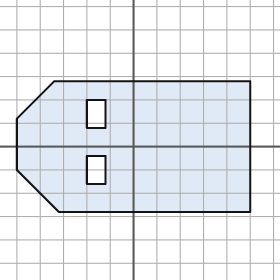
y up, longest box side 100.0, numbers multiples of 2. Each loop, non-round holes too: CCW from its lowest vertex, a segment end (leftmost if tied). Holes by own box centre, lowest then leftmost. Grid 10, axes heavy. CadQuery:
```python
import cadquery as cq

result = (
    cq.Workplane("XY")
    .moveTo(-32.0, -28.0)
    .lineTo(50.0, -28.0)
    .lineTo(50.0, 28.0)
    .lineTo(-34.0, 28.0)
    .lineTo(-50.0, 12.0)
    .lineTo(-50.0, -10.0)
    .close()
    .moveTo(-20.0, -16.0)
    .lineTo(-12.0, -16.0)
    .lineTo(-12.0, -4.0)
    .lineTo(-20.0, -4.0)
    .close()
    .moveTo(-20.0, 8.0)
    .lineTo(-12.0, 8.0)
    .lineTo(-12.0, 20.0)
    .lineTo(-20.0, 20.0)
    .close()
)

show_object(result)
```